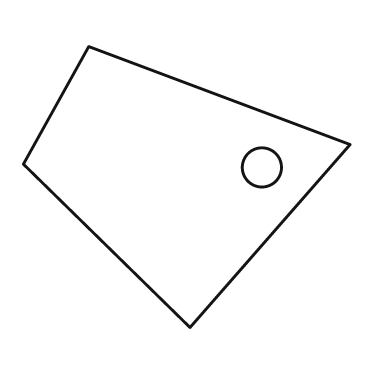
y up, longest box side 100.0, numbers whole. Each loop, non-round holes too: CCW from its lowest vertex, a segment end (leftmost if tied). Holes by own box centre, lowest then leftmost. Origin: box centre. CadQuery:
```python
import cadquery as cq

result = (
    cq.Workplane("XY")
    .moveTo(1.0, -43.0)
    .lineTo(50.0, 13.0)
    .lineTo(-30.0, 43.0)
    .lineTo(-50.0, 7.0)
    .close()
    .moveTo(23.0, 6.0)
    .circle(6.0)
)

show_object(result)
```